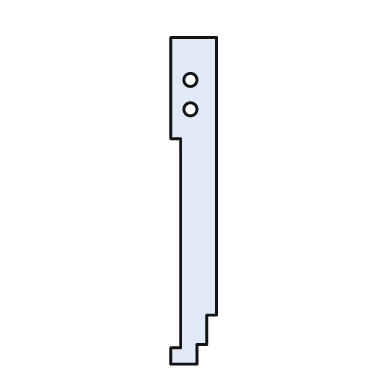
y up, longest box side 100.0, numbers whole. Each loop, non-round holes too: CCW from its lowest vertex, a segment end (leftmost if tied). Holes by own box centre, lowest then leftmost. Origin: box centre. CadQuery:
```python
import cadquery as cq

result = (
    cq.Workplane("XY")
    .moveTo(-7.0, -50.0)
    .lineTo(1.0, -50.0)
    .lineTo(1.0, -44.0)
    .lineTo(4.0, -44.0)
    .lineTo(4.0, -35.0)
    .lineTo(7.0, -35.0)
    .lineTo(7.0, 50.0)
    .lineTo(-7.0, 50.0)
    .lineTo(-7.0, 19.0)
    .lineTo(-4.0, 19.0)
    .lineTo(-4.0, -45.0)
    .lineTo(-7.0, -45.0)
    .close()
    .moveTo(-1.0, 28.0)
    .circle(2.0)
    .moveTo(-1.0, 37.0)
    .circle(2.0)
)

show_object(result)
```